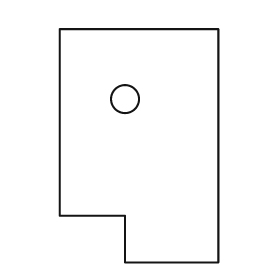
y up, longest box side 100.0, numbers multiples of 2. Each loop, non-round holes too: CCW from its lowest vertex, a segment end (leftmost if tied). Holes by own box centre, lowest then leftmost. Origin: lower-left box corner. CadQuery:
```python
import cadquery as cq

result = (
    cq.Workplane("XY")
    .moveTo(28.0, 0.0)
    .lineTo(68.0, 0.0)
    .lineTo(68.0, 100.0)
    .lineTo(0.0, 100.0)
    .lineTo(0.0, 20.0)
    .lineTo(28.0, 20.0)
    .close()
    .moveTo(28.0, 70.0)
    .circle(6.0)
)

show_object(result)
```